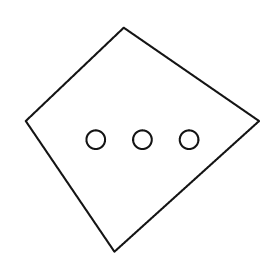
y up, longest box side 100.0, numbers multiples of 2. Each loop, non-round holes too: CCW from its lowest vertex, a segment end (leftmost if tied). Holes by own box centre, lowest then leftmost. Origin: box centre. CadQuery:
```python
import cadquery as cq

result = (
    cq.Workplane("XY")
    .moveTo(-12.0, -48.0)
    .lineTo(50.0, 8.0)
    .lineTo(-8.0, 48.0)
    .lineTo(-50.0, 8.0)
    .close()
    .moveTo(-20.0, 0.0)
    .circle(4.0)
    .moveTo(0.0, 0.0)
    .circle(4.0)
    .moveTo(20.0, 0.0)
    .circle(4.0)
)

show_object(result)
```